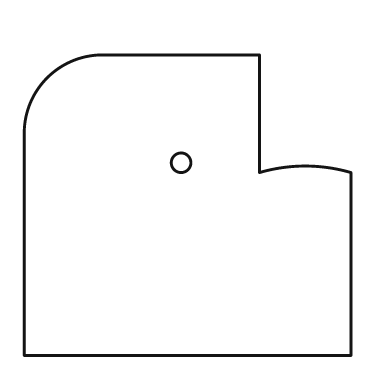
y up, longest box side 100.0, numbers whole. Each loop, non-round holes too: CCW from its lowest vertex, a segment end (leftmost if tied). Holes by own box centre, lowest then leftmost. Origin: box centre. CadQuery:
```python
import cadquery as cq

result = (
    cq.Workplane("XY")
    .moveTo(-50.0, -46.0)
    .lineTo(50.0, -46.0)
    .lineTo(50.0, 10.0)
    .threePointArc((36.0, 12.0), (22.0, 10.0))
    .lineTo(22.0, 46.0)
    .lineTo(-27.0, 46.0)
    .threePointArc((-43.0, 39.0), (-50.0, 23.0))
    .close()
    .moveTo(-2.0, 13.0)
    .circle(3.0)
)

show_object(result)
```